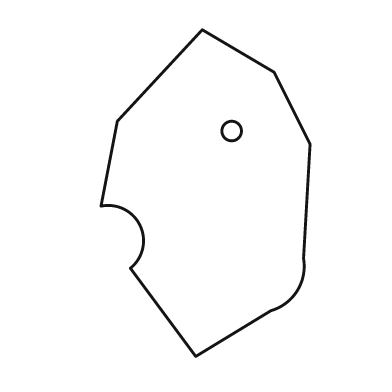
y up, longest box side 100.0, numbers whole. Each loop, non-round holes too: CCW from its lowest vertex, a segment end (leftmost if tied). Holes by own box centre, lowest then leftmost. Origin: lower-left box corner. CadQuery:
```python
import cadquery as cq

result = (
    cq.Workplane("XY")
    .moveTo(29.0, 0.0)
    .lineTo(52.0, 14.0)
    .threePointArc((60.0, 20.0), (62.0, 30.0))
    .lineTo(64.0, 65.0)
    .lineTo(53.0, 87.0)
    .lineTo(31.0, 100.0)
    .lineTo(5.0, 72.0)
    .lineTo(0.0, 46.0)
    .threePointArc((12.0, 40.0), (9.0, 27.0))
    .close()
    .moveTo(40.0, 69.0)
    .circle(3.0)
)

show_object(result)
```